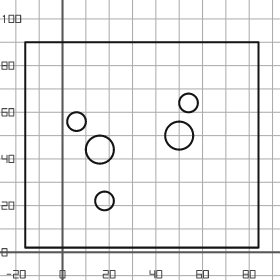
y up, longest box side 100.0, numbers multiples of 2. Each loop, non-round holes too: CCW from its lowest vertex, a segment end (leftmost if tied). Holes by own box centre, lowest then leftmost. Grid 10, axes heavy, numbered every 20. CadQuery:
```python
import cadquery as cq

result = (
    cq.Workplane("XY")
    .moveTo(-16.0, 2.0)
    .lineTo(84.0, 2.0)
    .lineTo(84.0, 90.0)
    .lineTo(-16.0, 90.0)
    .close()
    .moveTo(18.0, 22.0)
    .circle(4.0)
    .moveTo(16.0, 44.0)
    .circle(6.0)
    .moveTo(50.0, 50.0)
    .circle(6.0)
    .moveTo(6.0, 56.0)
    .circle(4.0)
    .moveTo(54.0, 64.0)
    .circle(4.0)
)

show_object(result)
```